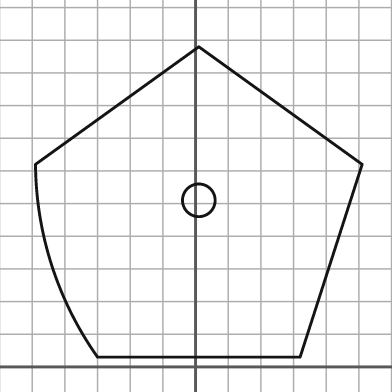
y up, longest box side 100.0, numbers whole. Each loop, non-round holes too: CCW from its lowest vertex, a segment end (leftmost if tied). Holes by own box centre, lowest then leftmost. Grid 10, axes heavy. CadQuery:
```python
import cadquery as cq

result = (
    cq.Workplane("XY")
    .moveTo(-30.0, 3.0)
    .lineTo(32.0, 3.0)
    .lineTo(51.0, 62.0)
    .lineTo(1.0, 98.0)
    .lineTo(-49.0, 62.0)
    .threePointArc((-44.0, 31.0), (-30.0, 3.0))
    .close()
    .moveTo(1.0, 51.0)
    .circle(5.0)
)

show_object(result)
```